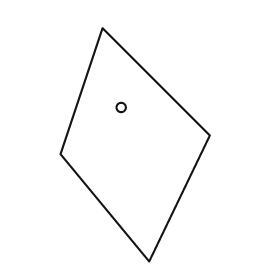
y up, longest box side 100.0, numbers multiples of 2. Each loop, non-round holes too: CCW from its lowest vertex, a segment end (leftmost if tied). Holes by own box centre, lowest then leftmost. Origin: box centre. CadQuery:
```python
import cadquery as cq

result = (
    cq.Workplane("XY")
    .moveTo(6.0, -50.0)
    .lineTo(32.0, 4.0)
    .lineTo(-14.0, 50.0)
    .lineTo(-32.0, -4.0)
    .close()
    .moveTo(-6.0, 16.0)
    .circle(2.0)
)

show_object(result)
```